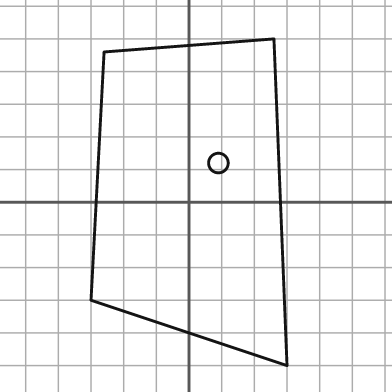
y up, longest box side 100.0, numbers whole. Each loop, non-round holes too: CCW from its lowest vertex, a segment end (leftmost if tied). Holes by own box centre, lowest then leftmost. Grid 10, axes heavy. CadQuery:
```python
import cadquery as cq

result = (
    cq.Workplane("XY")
    .moveTo(30.0, -50.0)
    .lineTo(26.0, 50.0)
    .lineTo(-26.0, 46.0)
    .lineTo(-30.0, -30.0)
    .close()
    .moveTo(9.0, 12.0)
    .circle(3.0)
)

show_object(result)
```